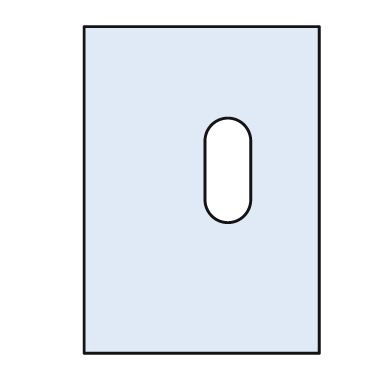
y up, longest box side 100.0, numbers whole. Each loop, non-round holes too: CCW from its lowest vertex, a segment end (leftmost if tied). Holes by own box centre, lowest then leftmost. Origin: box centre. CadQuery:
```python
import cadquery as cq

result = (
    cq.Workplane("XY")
    .moveTo(-36.0, -50.0)
    .lineTo(36.0, -50.0)
    .lineTo(36.0, 50.0)
    .lineTo(-36.0, 50.0)
    .close()
    .moveTo(1.0, -3.0)
    .threePointArc((8.0, -10.0), (15.0, -3.0))
    .lineTo(15.0, 15.0)
    .threePointArc((8.0, 22.0), (1.0, 15.0))
    .close()
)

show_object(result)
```